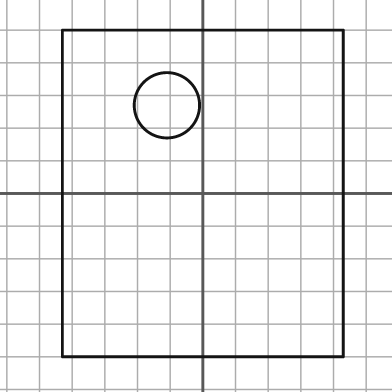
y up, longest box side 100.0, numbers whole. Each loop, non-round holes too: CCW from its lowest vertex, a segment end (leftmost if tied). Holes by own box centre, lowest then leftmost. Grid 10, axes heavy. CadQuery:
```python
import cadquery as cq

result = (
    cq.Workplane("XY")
    .moveTo(-43.0, -50.0)
    .lineTo(43.0, -50.0)
    .lineTo(43.0, 50.0)
    .lineTo(-43.0, 50.0)
    .close()
    .moveTo(-11.0, 27.0)
    .circle(10.0)
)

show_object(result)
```